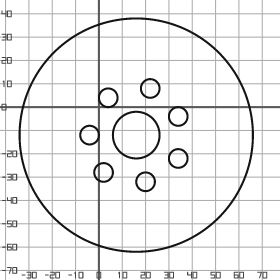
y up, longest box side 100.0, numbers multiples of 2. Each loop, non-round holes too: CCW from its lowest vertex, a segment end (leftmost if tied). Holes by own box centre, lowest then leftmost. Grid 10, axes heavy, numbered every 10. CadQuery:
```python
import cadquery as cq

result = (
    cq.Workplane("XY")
    .moveTo(16.0, -12.0)
    .circle(50.0)
    .moveTo(20.0, -32.0)
    .circle(4.0)
    .moveTo(2.0, -28.0)
    .circle(4.0)
    .moveTo(34.0, -22.0)
    .circle(4.0)
    .moveTo(-4.0, -12.0)
    .circle(4.0)
    .moveTo(16.0, -12.0)
    .circle(10.0)
    .moveTo(34.0, -4.0)
    .circle(4.0)
    .moveTo(4.0, 4.0)
    .circle(4.0)
    .moveTo(22.0, 8.0)
    .circle(4.0)
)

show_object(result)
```